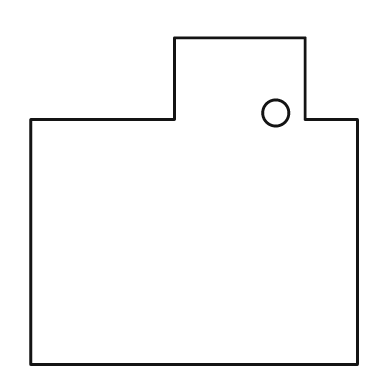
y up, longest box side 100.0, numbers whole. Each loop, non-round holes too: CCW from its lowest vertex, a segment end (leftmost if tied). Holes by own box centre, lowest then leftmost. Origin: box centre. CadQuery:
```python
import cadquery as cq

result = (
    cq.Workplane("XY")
    .moveTo(-50.0, -50.0)
    .lineTo(50.0, -50.0)
    .lineTo(50.0, 25.0)
    .lineTo(34.0, 25.0)
    .lineTo(34.0, 50.0)
    .lineTo(-6.0, 50.0)
    .lineTo(-6.0, 25.0)
    .lineTo(-50.0, 25.0)
    .close()
    .moveTo(25.0, 27.0)
    .circle(4.0)
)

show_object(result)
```